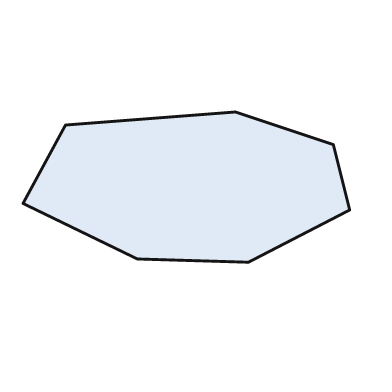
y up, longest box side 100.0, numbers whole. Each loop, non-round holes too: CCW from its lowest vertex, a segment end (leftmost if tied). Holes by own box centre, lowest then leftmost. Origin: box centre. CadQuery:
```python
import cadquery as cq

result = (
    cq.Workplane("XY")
    .moveTo(19.0, -23.0)
    .lineTo(50.0, -7.0)
    .lineTo(45.0, 13.0)
    .lineTo(15.0, 23.0)
    .lineTo(-37.0, 19.0)
    .lineTo(-50.0, -5.0)
    .lineTo(-15.0, -22.0)
    .close()
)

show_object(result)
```